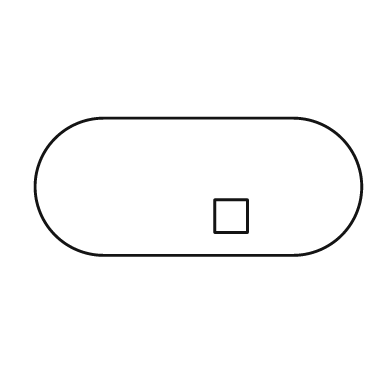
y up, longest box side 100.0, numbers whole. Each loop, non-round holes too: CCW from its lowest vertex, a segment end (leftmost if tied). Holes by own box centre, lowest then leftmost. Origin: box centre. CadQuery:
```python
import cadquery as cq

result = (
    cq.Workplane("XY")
    .moveTo(-29.0, -21.0)
    .lineTo(29.0, -21.0)
    .threePointArc((50.0, 0.0), (29.0, 21.0))
    .lineTo(-29.0, 21.0)
    .threePointArc((-50.0, 0.0), (-29.0, -21.0))
    .close()
    .moveTo(5.0, -14.0)
    .lineTo(15.0, -14.0)
    .lineTo(15.0, -4.0)
    .lineTo(5.0, -4.0)
    .close()
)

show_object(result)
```